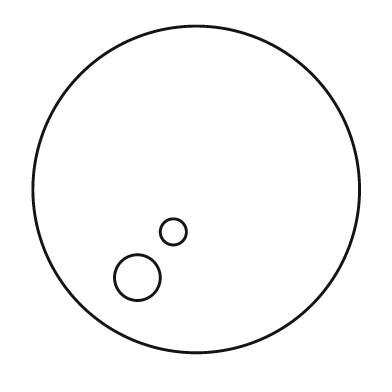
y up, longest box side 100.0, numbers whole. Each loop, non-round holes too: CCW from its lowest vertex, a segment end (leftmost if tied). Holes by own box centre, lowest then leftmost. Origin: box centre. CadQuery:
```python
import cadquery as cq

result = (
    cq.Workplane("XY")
    .moveTo(0.0, 0.0)
    .circle(50.0)
    .moveTo(-18.0, -27.0)
    .circle(7.0)
    .moveTo(-7.0, -13.0)
    .circle(4.0)
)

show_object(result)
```